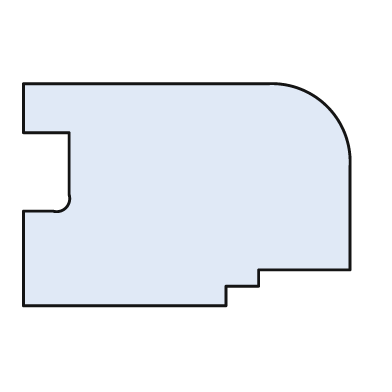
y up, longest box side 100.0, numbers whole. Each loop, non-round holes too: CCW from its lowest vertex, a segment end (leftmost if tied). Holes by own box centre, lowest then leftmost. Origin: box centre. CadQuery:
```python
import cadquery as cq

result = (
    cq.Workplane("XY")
    .moveTo(-50.0, -34.0)
    .lineTo(12.0, -34.0)
    .lineTo(12.0, -28.0)
    .lineTo(22.0, -28.0)
    .lineTo(22.0, -23.0)
    .lineTo(50.0, -23.0)
    .lineTo(50.0, 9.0)
    .threePointArc((43.0, 27.0), (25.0, 34.0))
    .lineTo(-50.0, 34.0)
    .lineTo(-50.0, 19.0)
    .lineTo(-36.0, 19.0)
    .lineTo(-36.0, 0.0)
    .threePointArc((-37.0, -4.0), (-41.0, -5.0))
    .lineTo(-50.0, -5.0)
    .close()
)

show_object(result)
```